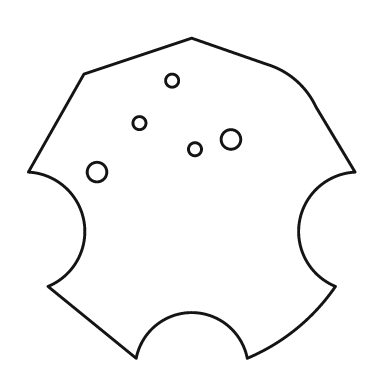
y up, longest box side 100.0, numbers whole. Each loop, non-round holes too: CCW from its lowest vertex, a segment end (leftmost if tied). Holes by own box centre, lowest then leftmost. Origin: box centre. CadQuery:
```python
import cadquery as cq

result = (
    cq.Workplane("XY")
    .moveTo(-17.0, -49.0)
    .threePointArc((0.0, -35.0), (17.0, -49.0))
    .threePointArc((32.0, -40.0), (44.0, -27.0))
    .threePointArc((33.0, -7.0), (50.0, 8.0))
    .lineTo(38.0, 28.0)
    .threePointArc((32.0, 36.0), (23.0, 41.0))
    .lineTo(0.0, 49.0)
    .lineTo(-33.0, 38.0)
    .lineTo(-50.0, 8.0)
    .threePointArc((-33.0, -7.0), (-44.0, -27.0))
    .close()
    .moveTo(-29.0, 8.0)
    .circle(3.0)
    .moveTo(1.0, 15.0)
    .circle(2.0)
    .moveTo(12.0, 18.0)
    .circle(3.0)
    .moveTo(-16.0, 23.0)
    .circle(2.0)
    .moveTo(-6.0, 36.0)
    .circle(2.0)
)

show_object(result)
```